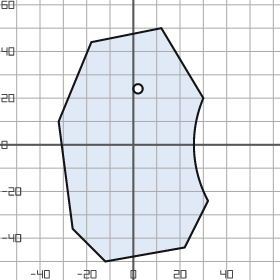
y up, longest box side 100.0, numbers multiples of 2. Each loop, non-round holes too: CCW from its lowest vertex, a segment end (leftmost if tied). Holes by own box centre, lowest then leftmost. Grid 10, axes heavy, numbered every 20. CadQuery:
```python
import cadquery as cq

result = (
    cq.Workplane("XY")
    .moveTo(-12.0, -50.0)
    .lineTo(22.0, -44.0)
    .lineTo(32.0, -24.0)
    .threePointArc((26.0, -2.0), (30.0, 20.0))
    .lineTo(12.0, 50.0)
    .lineTo(-18.0, 44.0)
    .lineTo(-32.0, 10.0)
    .lineTo(-26.0, -36.0)
    .close()
    .moveTo(2.0, 24.0)
    .circle(2.0)
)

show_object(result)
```